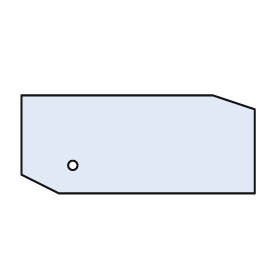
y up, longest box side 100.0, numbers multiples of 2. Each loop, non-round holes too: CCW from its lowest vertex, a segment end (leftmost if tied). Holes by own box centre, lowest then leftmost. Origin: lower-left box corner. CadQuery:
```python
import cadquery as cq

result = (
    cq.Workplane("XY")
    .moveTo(16.0, 0.0)
    .lineTo(100.0, 0.0)
    .lineTo(100.0, 36.0)
    .lineTo(82.0, 42.0)
    .lineTo(0.0, 42.0)
    .lineTo(0.0, 8.0)
    .close()
    .moveTo(22.0, 12.0)
    .circle(2.0)
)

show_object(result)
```